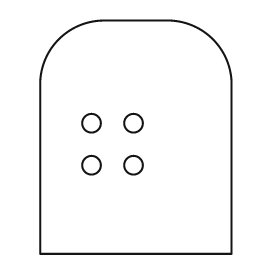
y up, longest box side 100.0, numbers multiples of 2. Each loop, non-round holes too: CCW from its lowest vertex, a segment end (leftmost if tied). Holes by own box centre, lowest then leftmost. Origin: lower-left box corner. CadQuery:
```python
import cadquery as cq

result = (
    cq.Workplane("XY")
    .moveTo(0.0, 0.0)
    .lineTo(82.0, 0.0)
    .lineTo(82.0, 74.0)
    .threePointArc((74.0, 92.0), (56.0, 100.0))
    .lineTo(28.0, 100.0)
    .threePointArc((8.0, 92.0), (0.0, 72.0))
    .close()
    .moveTo(22.0, 38.0)
    .circle(4.0)
    .moveTo(40.0, 38.0)
    .circle(4.0)
    .moveTo(22.0, 56.0)
    .circle(4.0)
    .moveTo(40.0, 56.0)
    .circle(4.0)
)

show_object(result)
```